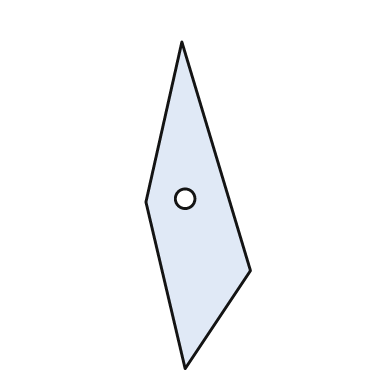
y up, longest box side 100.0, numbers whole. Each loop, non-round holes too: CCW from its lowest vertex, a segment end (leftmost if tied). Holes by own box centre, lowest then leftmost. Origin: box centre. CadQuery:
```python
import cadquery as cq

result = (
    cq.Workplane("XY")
    .moveTo(-4.0, -50.0)
    .lineTo(16.0, -20.0)
    .lineTo(-5.0, 50.0)
    .lineTo(-16.0, 1.0)
    .close()
    .moveTo(-4.0, 2.0)
    .circle(3.0)
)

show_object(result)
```